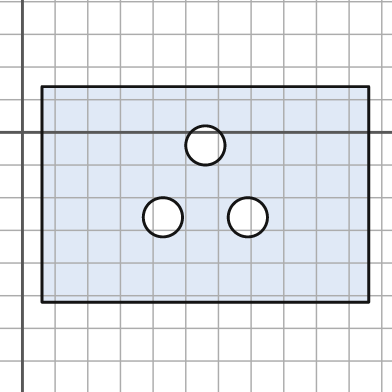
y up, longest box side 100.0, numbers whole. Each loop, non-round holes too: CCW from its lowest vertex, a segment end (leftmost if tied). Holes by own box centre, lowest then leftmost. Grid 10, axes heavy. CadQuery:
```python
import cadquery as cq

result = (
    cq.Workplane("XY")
    .moveTo(6.0, -52.0)
    .lineTo(106.0, -52.0)
    .lineTo(106.0, 14.0)
    .lineTo(6.0, 14.0)
    .close()
    .moveTo(43.0, -26.0)
    .circle(6.0)
    .moveTo(69.0, -26.0)
    .circle(6.0)
    .moveTo(56.0, -4.0)
    .circle(6.0)
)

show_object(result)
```